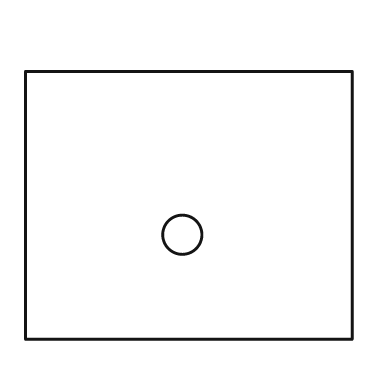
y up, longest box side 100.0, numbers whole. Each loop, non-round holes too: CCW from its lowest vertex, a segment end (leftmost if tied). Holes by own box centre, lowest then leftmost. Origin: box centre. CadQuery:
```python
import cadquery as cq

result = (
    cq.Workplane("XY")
    .moveTo(-50.0, -41.0)
    .lineTo(50.0, -41.0)
    .lineTo(50.0, 41.0)
    .lineTo(-50.0, 41.0)
    .close()
    .moveTo(-2.0, -9.0)
    .circle(6.0)
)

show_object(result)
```